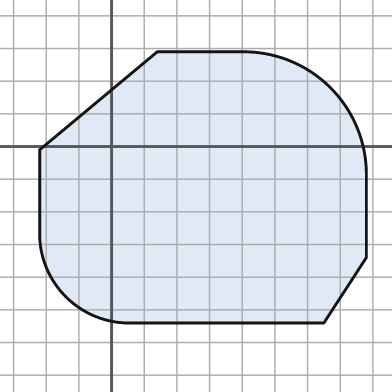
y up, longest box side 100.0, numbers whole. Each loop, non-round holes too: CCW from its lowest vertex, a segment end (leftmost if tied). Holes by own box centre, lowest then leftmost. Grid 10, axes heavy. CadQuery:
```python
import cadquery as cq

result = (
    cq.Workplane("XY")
    .moveTo(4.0, -54.0)
    .lineTo(65.0, -54.0)
    .lineTo(78.0, -34.0)
    .lineTo(78.0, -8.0)
    .threePointArc((67.0, 18.0), (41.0, 29.0))
    .lineTo(14.0, 29.0)
    .lineTo(-22.0, -1.0)
    .lineTo(-22.0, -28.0)
    .threePointArc((-14.0, -46.0), (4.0, -54.0))
    .close()
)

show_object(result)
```